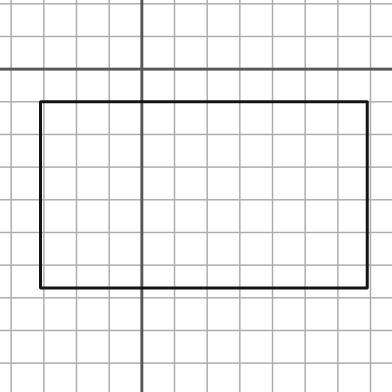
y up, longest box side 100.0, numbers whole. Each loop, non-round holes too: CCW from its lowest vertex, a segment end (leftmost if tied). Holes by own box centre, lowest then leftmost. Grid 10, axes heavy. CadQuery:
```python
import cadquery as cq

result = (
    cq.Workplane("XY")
    .moveTo(-31.0, -67.0)
    .lineTo(69.0, -67.0)
    .lineTo(69.0, -10.0)
    .lineTo(-31.0, -10.0)
    .close()
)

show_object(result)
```